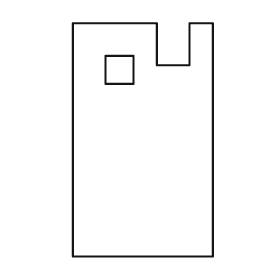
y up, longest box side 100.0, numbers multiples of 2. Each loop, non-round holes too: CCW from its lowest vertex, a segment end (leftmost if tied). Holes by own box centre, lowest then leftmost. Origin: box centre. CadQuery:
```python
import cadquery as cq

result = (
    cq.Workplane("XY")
    .moveTo(-30.0, -50.0)
    .lineTo(30.0, -50.0)
    .lineTo(30.0, 50.0)
    .lineTo(20.0, 50.0)
    .lineTo(20.0, 32.0)
    .lineTo(6.0, 32.0)
    .lineTo(6.0, 50.0)
    .lineTo(-30.0, 50.0)
    .close()
    .moveTo(-16.0, 24.0)
    .lineTo(-4.0, 24.0)
    .lineTo(-4.0, 36.0)
    .lineTo(-16.0, 36.0)
    .close()
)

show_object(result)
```